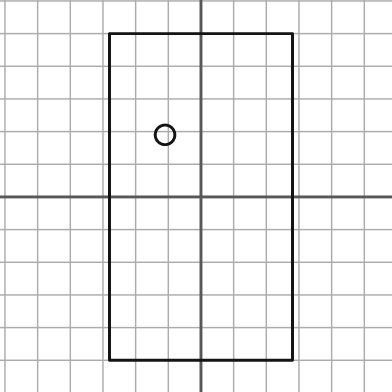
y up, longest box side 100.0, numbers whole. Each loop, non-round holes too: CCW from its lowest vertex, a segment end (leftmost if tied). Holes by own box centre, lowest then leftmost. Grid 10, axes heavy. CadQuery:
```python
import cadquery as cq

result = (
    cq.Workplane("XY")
    .moveTo(-28.0, -50.0)
    .lineTo(28.0, -50.0)
    .lineTo(28.0, 50.0)
    .lineTo(-28.0, 50.0)
    .close()
    .moveTo(-11.0, 19.0)
    .circle(3.0)
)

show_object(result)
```